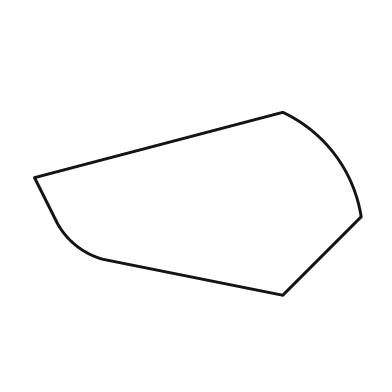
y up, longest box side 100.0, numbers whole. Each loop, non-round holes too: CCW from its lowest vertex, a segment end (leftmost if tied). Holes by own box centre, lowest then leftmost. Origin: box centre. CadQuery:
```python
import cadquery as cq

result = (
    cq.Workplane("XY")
    .moveTo(26.0, -28.0)
    .lineTo(50.0, -4.0)
    .threePointArc((42.0, 15.0), (26.0, 28.0))
    .lineTo(-50.0, 8.0)
    .lineTo(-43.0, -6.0)
    .threePointArc((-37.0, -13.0), (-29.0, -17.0))
    .close()
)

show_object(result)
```